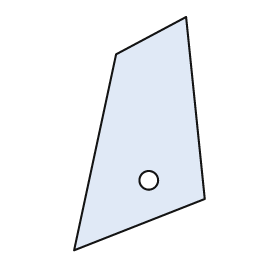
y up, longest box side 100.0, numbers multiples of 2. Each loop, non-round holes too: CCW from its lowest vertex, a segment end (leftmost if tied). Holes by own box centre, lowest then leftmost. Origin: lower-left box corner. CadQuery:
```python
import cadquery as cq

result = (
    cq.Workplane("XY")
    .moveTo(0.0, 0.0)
    .lineTo(56.0, 22.0)
    .lineTo(48.0, 100.0)
    .lineTo(18.0, 84.0)
    .close()
    .moveTo(32.0, 30.0)
    .circle(4.0)
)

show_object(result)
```